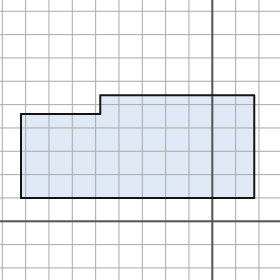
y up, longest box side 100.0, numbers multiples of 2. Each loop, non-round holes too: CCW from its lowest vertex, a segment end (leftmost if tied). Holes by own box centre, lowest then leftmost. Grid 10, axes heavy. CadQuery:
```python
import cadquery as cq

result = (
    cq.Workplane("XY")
    .moveTo(-82.0, 10.0)
    .lineTo(18.0, 10.0)
    .lineTo(18.0, 54.0)
    .lineTo(-48.0, 54.0)
    .lineTo(-48.0, 46.0)
    .lineTo(-82.0, 46.0)
    .close()
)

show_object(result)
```